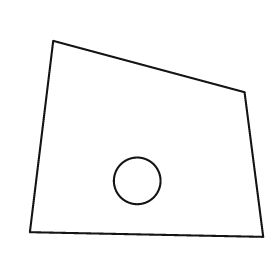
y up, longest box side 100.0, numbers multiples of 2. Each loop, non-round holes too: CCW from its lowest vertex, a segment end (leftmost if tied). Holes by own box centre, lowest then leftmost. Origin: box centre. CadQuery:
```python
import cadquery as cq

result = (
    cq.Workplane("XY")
    .moveTo(50.0, -42.0)
    .lineTo(42.0, 20.0)
    .lineTo(-40.0, 42.0)
    .lineTo(-50.0, -40.0)
    .close()
    .moveTo(-4.0, -18.0)
    .circle(10.0)
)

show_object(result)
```